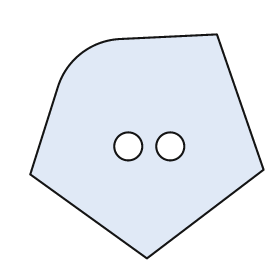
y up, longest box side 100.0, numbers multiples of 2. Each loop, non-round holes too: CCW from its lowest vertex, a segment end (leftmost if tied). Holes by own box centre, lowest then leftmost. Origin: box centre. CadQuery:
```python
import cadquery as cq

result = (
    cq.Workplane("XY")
    .moveTo(0.0, -48.0)
    .lineTo(50.0, -10.0)
    .lineTo(30.0, 48.0)
    .lineTo(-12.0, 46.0)
    .threePointArc((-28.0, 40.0), (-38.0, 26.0))
    .lineTo(-50.0, -12.0)
    .close()
    .moveTo(-8.0, 0.0)
    .circle(6.0)
    .moveTo(10.0, 0.0)
    .circle(6.0)
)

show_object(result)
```